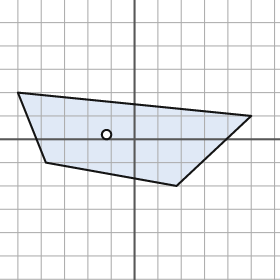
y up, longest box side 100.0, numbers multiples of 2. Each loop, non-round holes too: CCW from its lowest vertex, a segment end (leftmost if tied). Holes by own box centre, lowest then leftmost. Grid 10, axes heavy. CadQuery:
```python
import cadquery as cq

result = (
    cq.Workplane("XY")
    .moveTo(18.0, -20.0)
    .lineTo(50.0, 10.0)
    .lineTo(-50.0, 20.0)
    .lineTo(-38.0, -10.0)
    .close()
    .moveTo(-12.0, 2.0)
    .circle(2.0)
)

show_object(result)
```